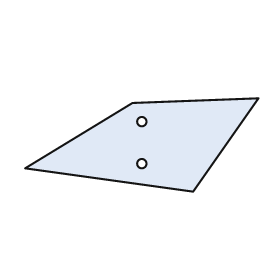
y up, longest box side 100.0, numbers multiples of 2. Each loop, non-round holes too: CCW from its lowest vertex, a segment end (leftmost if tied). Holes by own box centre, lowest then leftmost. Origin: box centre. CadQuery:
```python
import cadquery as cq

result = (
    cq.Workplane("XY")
    .moveTo(22.0, -20.0)
    .lineTo(50.0, 20.0)
    .lineTo(-4.0, 18.0)
    .lineTo(-50.0, -10.0)
    .close()
    .moveTo(0.0, -8.0)
    .circle(2.0)
    .moveTo(0.0, 10.0)
    .circle(2.0)
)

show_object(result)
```